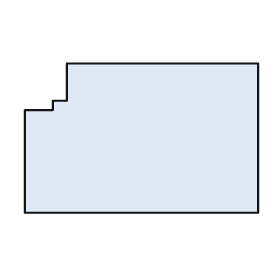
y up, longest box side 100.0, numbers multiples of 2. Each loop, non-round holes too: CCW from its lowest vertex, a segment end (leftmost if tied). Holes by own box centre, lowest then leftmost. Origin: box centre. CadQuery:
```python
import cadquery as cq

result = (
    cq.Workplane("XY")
    .moveTo(-50.0, -32.0)
    .lineTo(50.0, -32.0)
    .lineTo(50.0, 32.0)
    .lineTo(-32.0, 32.0)
    .lineTo(-32.0, 16.0)
    .lineTo(-38.0, 16.0)
    .lineTo(-38.0, 12.0)
    .lineTo(-50.0, 12.0)
    .close()
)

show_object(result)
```